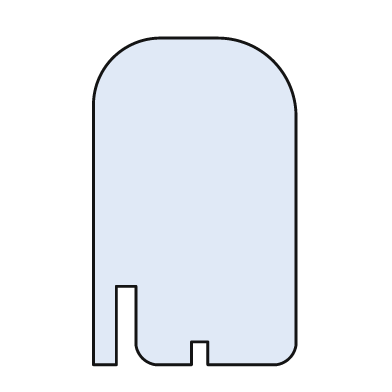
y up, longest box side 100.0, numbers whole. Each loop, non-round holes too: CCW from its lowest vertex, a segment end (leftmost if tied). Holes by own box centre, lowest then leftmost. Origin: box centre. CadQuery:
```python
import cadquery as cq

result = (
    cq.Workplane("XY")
    .moveTo(-31.0, -50.0)
    .lineTo(-24.0, -50.0)
    .lineTo(-24.0, -26.0)
    .lineTo(-18.0, -26.0)
    .lineTo(-18.0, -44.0)
    .threePointArc((-16.0, -48.0), (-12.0, -50.0))
    .lineTo(-1.0, -50.0)
    .lineTo(-1.0, -43.0)
    .lineTo(4.0, -43.0)
    .lineTo(4.0, -50.0)
    .lineTo(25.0, -50.0)
    .threePointArc((29.0, -48.0), (31.0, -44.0))
    .lineTo(31.0, 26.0)
    .threePointArc((24.0, 43.0), (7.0, 50.0))
    .lineTo(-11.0, 50.0)
    .threePointArc((-25.0, 44.0), (-31.0, 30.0))
    .close()
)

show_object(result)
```